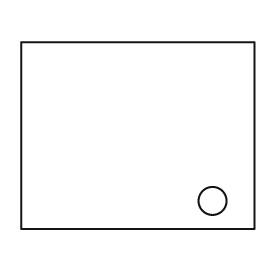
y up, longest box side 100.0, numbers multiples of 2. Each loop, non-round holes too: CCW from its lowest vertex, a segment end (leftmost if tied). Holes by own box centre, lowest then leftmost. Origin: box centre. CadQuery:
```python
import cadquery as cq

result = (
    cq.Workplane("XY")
    .moveTo(-50.0, -40.0)
    .lineTo(50.0, -40.0)
    .lineTo(50.0, 40.0)
    .lineTo(-50.0, 40.0)
    .close()
    .moveTo(32.0, -28.0)
    .circle(6.0)
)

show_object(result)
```